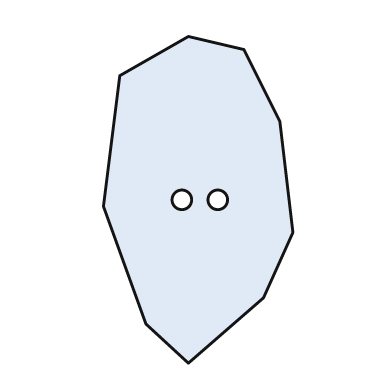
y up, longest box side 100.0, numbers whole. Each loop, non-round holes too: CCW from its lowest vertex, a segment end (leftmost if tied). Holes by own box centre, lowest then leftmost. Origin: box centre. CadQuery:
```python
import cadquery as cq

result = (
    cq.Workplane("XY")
    .moveTo(-3.0, -50.0)
    .lineTo(20.0, -30.0)
    .lineTo(29.0, -10.0)
    .lineTo(25.0, 24.0)
    .lineTo(14.0, 46.0)
    .lineTo(-3.0, 50.0)
    .lineTo(-24.0, 38.0)
    .lineTo(-29.0, -2.0)
    .lineTo(-16.0, -38.0)
    .close()
    .moveTo(-5.0, 0.0)
    .circle(3.0)
    .moveTo(6.0, 0.0)
    .circle(3.0)
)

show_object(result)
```